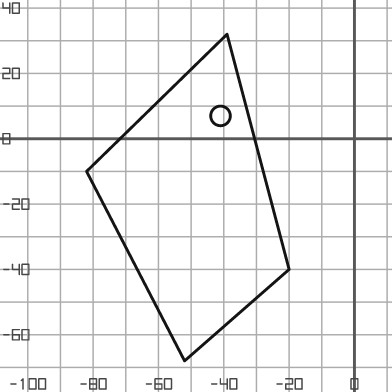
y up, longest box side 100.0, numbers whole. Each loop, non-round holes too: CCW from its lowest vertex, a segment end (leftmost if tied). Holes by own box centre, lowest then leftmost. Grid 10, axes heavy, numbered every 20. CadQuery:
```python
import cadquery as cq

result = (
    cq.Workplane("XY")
    .moveTo(-52.0, -68.0)
    .lineTo(-20.0, -40.0)
    .lineTo(-39.0, 32.0)
    .lineTo(-82.0, -10.0)
    .close()
    .moveTo(-41.0, 7.0)
    .circle(3.0)
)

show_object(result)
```